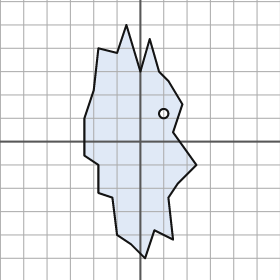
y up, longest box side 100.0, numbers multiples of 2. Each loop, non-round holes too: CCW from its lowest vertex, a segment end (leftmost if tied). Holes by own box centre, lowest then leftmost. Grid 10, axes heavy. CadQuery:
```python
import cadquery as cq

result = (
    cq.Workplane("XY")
    .moveTo(2.0, -50.0)
    .lineTo(6.0, -38.0)
    .lineTo(14.0, -42.0)
    .lineTo(12.0, -24.0)
    .lineTo(16.0, -18.0)
    .lineTo(24.0, -10.0)
    .lineTo(14.0, 4.0)
    .lineTo(18.0, 16.0)
    .lineTo(12.0, 26.0)
    .lineTo(8.0, 30.0)
    .lineTo(4.0, 44.0)
    .lineTo(0.0, 30.0)
    .lineTo(-6.0, 50.0)
    .lineTo(-10.0, 38.0)
    .lineTo(-18.0, 40.0)
    .lineTo(-20.0, 22.0)
    .lineTo(-24.0, 10.0)
    .lineTo(-24.0, -6.0)
    .lineTo(-18.0, -10.0)
    .lineTo(-18.0, -22.0)
    .lineTo(-12.0, -24.0)
    .lineTo(-10.0, -40.0)
    .lineTo(-4.0, -44.0)
    .close()
    .moveTo(10.0, 12.0)
    .circle(2.0)
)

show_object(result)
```